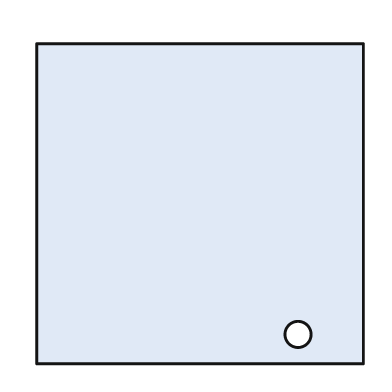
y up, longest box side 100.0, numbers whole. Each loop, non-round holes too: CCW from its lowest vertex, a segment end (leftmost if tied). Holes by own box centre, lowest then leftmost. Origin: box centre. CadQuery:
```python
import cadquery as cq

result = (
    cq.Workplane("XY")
    .moveTo(-50.0, -49.0)
    .lineTo(50.0, -49.0)
    .lineTo(50.0, 49.0)
    .lineTo(-50.0, 49.0)
    .close()
    .moveTo(30.0, -40.0)
    .circle(4.0)
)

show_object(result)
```